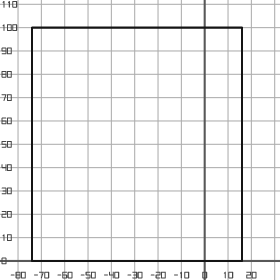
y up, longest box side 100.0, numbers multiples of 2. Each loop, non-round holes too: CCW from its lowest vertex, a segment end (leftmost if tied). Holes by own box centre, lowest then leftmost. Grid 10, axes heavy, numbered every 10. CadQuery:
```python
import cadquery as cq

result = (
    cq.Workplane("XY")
    .moveTo(-74.0, 0.0)
    .lineTo(16.0, 0.0)
    .lineTo(16.0, 100.0)
    .lineTo(-74.0, 100.0)
    .close()
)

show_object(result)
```